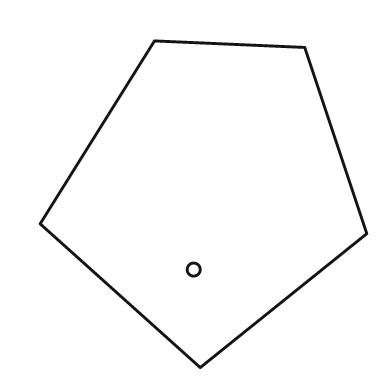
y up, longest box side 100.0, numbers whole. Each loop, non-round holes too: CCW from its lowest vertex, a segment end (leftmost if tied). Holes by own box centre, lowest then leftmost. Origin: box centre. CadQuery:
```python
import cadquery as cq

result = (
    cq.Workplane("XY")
    .moveTo(-1.0, -50.0)
    .lineTo(50.0, -9.0)
    .lineTo(31.0, 48.0)
    .lineTo(-15.0, 50.0)
    .lineTo(-50.0, -6.0)
    .close()
    .moveTo(-3.0, -20.0)
    .circle(2.0)
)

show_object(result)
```